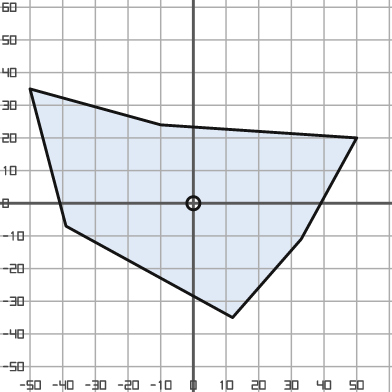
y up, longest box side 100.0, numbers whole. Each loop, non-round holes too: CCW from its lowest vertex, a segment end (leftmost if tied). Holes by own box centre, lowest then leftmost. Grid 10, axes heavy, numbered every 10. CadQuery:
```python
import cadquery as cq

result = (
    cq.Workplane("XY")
    .moveTo(12.0, -35.0)
    .lineTo(33.0, -11.0)
    .lineTo(50.0, 20.0)
    .lineTo(-10.0, 24.0)
    .lineTo(-50.0, 35.0)
    .lineTo(-39.0, -7.0)
    .close()
    .moveTo(0.0, 0.0)
    .circle(2.0)
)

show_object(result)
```